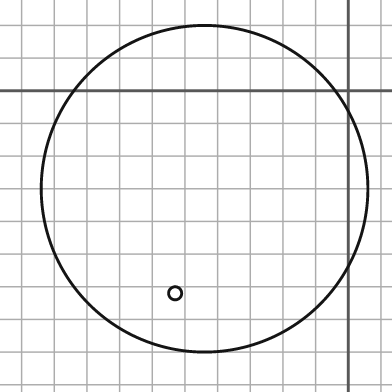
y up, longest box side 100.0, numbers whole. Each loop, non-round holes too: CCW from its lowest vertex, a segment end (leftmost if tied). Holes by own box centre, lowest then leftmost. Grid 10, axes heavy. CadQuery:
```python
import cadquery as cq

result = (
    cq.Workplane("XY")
    .moveTo(-44.0, -30.0)
    .circle(50.0)
    .moveTo(-53.0, -62.0)
    .circle(2.0)
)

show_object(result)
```